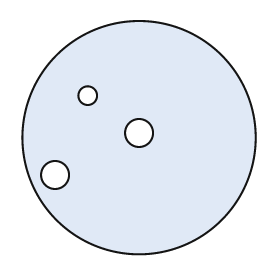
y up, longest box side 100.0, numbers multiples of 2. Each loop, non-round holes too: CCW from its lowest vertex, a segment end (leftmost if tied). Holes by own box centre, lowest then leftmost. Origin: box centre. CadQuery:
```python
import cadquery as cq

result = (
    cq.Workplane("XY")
    .moveTo(0.0, 0.0)
    .circle(50.0)
    .moveTo(-36.0, -16.0)
    .circle(6.0)
    .moveTo(0.0, 2.0)
    .circle(6.0)
    .moveTo(-22.0, 18.0)
    .circle(4.0)
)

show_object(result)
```